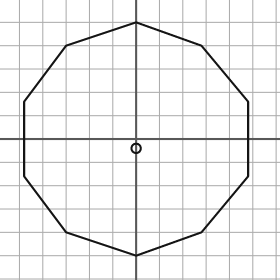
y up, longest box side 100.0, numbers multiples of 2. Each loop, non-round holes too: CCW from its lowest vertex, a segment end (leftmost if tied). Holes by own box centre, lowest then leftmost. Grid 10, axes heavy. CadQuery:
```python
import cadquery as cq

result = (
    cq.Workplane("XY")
    .moveTo(0.0, -50.0)
    .lineTo(28.0, -40.0)
    .lineTo(48.0, -16.0)
    .lineTo(48.0, 16.0)
    .lineTo(28.0, 40.0)
    .lineTo(0.0, 50.0)
    .lineTo(-30.0, 40.0)
    .lineTo(-48.0, 16.0)
    .lineTo(-48.0, -16.0)
    .lineTo(-30.0, -40.0)
    .close()
    .moveTo(0.0, -4.0)
    .circle(2.0)
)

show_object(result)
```